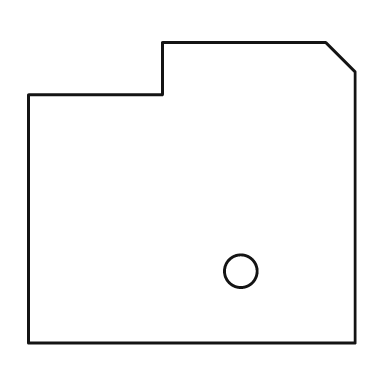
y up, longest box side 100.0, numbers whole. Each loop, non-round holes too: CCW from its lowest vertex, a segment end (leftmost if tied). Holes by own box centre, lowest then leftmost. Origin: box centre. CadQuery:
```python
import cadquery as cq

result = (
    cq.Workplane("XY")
    .moveTo(-50.0, -46.0)
    .lineTo(50.0, -46.0)
    .lineTo(50.0, 37.0)
    .lineTo(41.0, 46.0)
    .lineTo(-9.0, 46.0)
    .lineTo(-9.0, 30.0)
    .lineTo(-50.0, 30.0)
    .close()
    .moveTo(15.0, -24.0)
    .circle(5.0)
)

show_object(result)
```